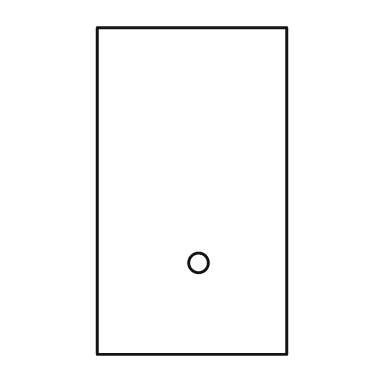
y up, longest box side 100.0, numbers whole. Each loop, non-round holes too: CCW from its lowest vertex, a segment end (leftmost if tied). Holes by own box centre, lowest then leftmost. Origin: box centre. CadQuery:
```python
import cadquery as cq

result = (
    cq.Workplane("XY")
    .moveTo(-29.0, -50.0)
    .lineTo(29.0, -50.0)
    .lineTo(29.0, 50.0)
    .lineTo(-29.0, 50.0)
    .close()
    .moveTo(2.0, -22.0)
    .circle(3.0)
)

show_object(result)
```